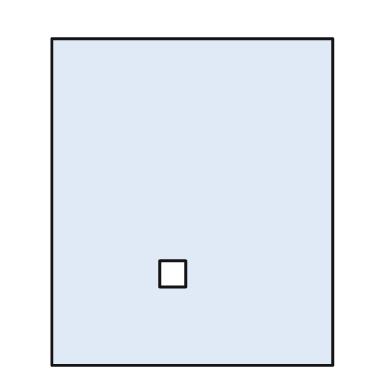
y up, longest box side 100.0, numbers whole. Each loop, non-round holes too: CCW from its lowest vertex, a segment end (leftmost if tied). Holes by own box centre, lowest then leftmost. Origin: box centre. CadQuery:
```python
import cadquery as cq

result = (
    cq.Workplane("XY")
    .moveTo(-43.0, -50.0)
    .lineTo(43.0, -50.0)
    .lineTo(43.0, 50.0)
    .lineTo(-43.0, 50.0)
    .close()
    .moveTo(-10.0, -26.0)
    .lineTo(-2.0, -26.0)
    .lineTo(-2.0, -18.0)
    .lineTo(-10.0, -18.0)
    .close()
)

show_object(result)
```